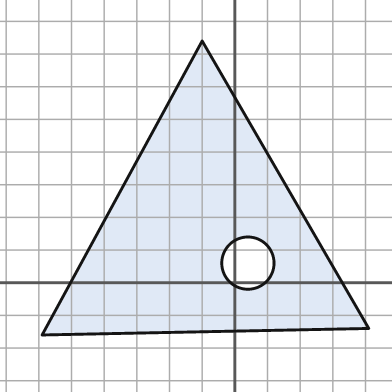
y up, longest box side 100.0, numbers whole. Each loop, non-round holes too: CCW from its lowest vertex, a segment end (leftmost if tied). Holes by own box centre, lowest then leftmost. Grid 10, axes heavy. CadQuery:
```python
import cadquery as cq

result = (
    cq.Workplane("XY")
    .moveTo(-59.0, -16.0)
    .lineTo(41.0, -14.0)
    .lineTo(-10.0, 74.0)
    .close()
    .moveTo(4.0, 6.0)
    .circle(8.0)
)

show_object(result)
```